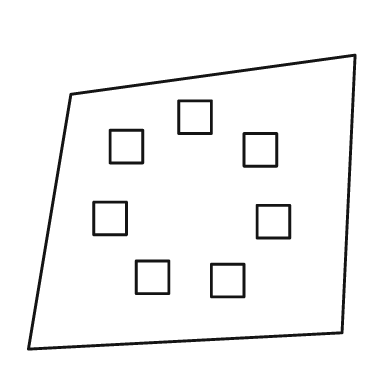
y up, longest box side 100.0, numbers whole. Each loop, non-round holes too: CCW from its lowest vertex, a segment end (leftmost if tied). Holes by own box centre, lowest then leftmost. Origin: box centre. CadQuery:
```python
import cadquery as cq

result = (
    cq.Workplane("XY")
    .moveTo(-50.0, -45.0)
    .lineTo(46.0, -40.0)
    .lineTo(50.0, 45.0)
    .lineTo(-37.0, 33.0)
    .close()
    .moveTo(6.0, -29.0)
    .lineTo(16.0, -29.0)
    .lineTo(16.0, -19.0)
    .lineTo(6.0, -19.0)
    .close()
    .moveTo(-17.0, -28.0)
    .lineTo(-7.0, -28.0)
    .lineTo(-7.0, -18.0)
    .lineTo(-17.0, -18.0)
    .close()
    .moveTo(20.0, -11.0)
    .lineTo(30.0, -11.0)
    .lineTo(30.0, -1.0)
    .lineTo(20.0, -1.0)
    .close()
    .moveTo(-30.0, -10.0)
    .lineTo(-20.0, -10.0)
    .lineTo(-20.0, 0.0)
    .lineTo(-30.0, 0.0)
    .close()
    .moveTo(16.0, 11.0)
    .lineTo(26.0, 11.0)
    .lineTo(26.0, 21.0)
    .lineTo(16.0, 21.0)
    .close()
    .moveTo(-25.0, 12.0)
    .lineTo(-15.0, 12.0)
    .lineTo(-15.0, 22.0)
    .lineTo(-25.0, 22.0)
    .close()
    .moveTo(-4.0, 21.0)
    .lineTo(6.0, 21.0)
    .lineTo(6.0, 31.0)
    .lineTo(-4.0, 31.0)
    .close()
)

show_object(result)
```